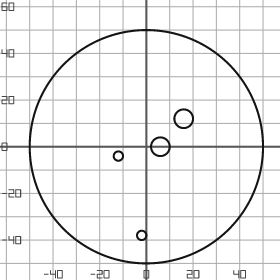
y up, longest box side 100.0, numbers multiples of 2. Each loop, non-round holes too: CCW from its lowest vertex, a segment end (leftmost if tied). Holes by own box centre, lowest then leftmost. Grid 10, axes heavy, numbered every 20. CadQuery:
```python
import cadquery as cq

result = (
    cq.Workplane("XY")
    .moveTo(0.0, 0.0)
    .circle(50.0)
    .moveTo(-2.0, -38.0)
    .circle(2.0)
    .moveTo(-12.0, -4.0)
    .circle(2.0)
    .moveTo(6.0, 0.0)
    .circle(4.0)
    .moveTo(16.0, 12.0)
    .circle(4.0)
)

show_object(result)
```